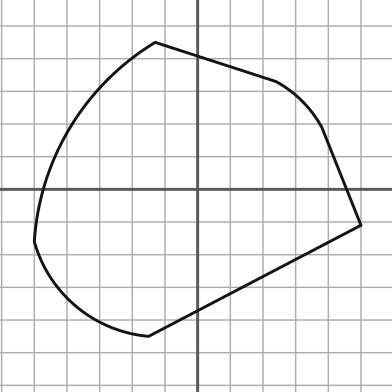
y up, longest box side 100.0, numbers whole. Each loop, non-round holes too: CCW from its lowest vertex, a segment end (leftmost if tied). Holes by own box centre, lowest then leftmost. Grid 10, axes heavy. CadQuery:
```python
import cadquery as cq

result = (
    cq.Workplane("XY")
    .moveTo(-15.0, -45.0)
    .lineTo(50.0, -11.0)
    .lineTo(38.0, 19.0)
    .threePointArc((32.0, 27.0), (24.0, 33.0))
    .lineTo(-13.0, 45.0)
    .threePointArc((-39.0, 19.0), (-50.0, -16.0))
    .threePointArc((-37.0, -36.0), (-15.0, -45.0))
    .close()
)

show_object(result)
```